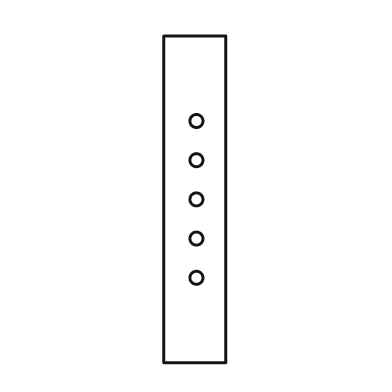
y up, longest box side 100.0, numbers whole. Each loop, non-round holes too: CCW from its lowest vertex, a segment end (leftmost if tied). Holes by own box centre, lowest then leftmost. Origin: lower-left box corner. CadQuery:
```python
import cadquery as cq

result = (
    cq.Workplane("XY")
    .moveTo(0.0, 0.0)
    .lineTo(19.0, 0.0)
    .lineTo(19.0, 100.0)
    .lineTo(0.0, 100.0)
    .close()
    .moveTo(10.0, 26.0)
    .circle(2.0)
    .moveTo(10.0, 38.0)
    .circle(2.0)
    .moveTo(10.0, 50.0)
    .circle(2.0)
    .moveTo(10.0, 62.0)
    .circle(2.0)
    .moveTo(10.0, 74.0)
    .circle(2.0)
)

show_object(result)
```